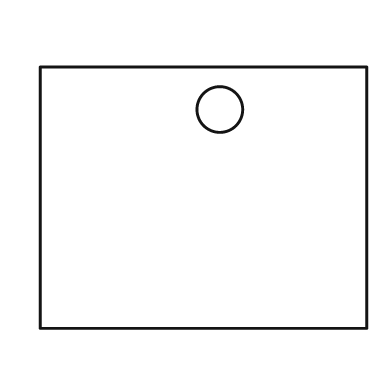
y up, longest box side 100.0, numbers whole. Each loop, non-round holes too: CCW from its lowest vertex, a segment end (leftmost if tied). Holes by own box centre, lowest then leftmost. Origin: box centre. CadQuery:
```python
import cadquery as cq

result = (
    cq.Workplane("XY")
    .moveTo(-50.0, -40.0)
    .lineTo(50.0, -40.0)
    .lineTo(50.0, 40.0)
    .lineTo(-50.0, 40.0)
    .close()
    .moveTo(5.0, 27.0)
    .circle(7.0)
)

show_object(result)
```